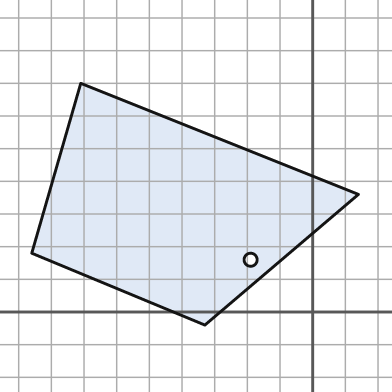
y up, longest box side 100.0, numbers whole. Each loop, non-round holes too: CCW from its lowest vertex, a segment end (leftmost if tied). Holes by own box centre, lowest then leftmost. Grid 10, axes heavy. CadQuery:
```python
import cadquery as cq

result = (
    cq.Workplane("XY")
    .moveTo(-33.0, -4.0)
    .lineTo(14.0, 36.0)
    .lineTo(-71.0, 70.0)
    .lineTo(-86.0, 18.0)
    .close()
    .moveTo(-19.0, 16.0)
    .circle(2.0)
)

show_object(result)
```